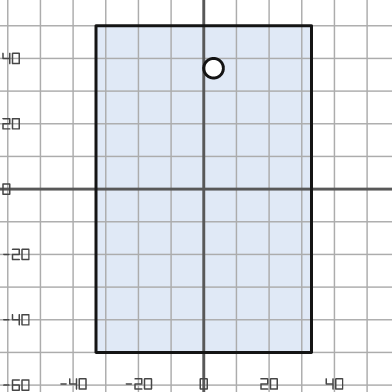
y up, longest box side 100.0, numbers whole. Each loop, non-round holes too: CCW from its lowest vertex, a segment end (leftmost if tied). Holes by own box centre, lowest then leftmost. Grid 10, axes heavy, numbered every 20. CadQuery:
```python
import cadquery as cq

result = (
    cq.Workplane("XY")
    .moveTo(-33.0, -50.0)
    .lineTo(33.0, -50.0)
    .lineTo(33.0, 50.0)
    .lineTo(-33.0, 50.0)
    .close()
    .moveTo(3.0, 37.0)
    .circle(3.0)
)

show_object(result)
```